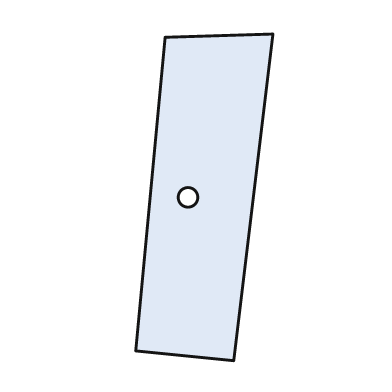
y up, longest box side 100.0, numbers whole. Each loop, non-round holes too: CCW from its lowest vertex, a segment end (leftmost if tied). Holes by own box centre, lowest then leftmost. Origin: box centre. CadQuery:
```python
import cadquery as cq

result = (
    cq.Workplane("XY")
    .moveTo(9.0, -50.0)
    .lineTo(21.0, 50.0)
    .lineTo(-12.0, 49.0)
    .lineTo(-21.0, -47.0)
    .close()
    .moveTo(-5.0, 0.0)
    .circle(3.0)
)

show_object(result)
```